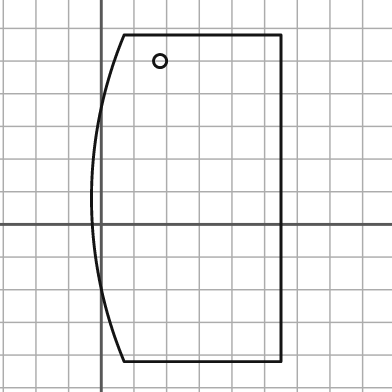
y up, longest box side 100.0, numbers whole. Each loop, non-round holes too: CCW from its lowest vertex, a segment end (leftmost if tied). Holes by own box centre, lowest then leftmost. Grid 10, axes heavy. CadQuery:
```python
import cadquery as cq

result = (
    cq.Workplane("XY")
    .moveTo(7.0, -42.0)
    .lineTo(55.0, -42.0)
    .lineTo(55.0, 58.0)
    .lineTo(7.0, 58.0)
    .threePointArc((-3.0, 8.0), (7.0, -42.0))
    .close()
    .moveTo(18.0, 50.0)
    .circle(2.0)
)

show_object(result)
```